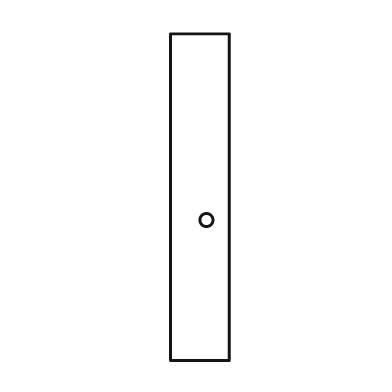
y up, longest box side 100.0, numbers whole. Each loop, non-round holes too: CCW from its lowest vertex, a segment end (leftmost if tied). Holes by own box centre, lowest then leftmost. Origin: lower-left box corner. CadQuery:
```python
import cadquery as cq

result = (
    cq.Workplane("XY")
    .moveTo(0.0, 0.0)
    .lineTo(18.0, 0.0)
    .lineTo(18.0, 100.0)
    .lineTo(0.0, 100.0)
    .close()
    .moveTo(11.0, 43.0)
    .circle(2.0)
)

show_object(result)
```